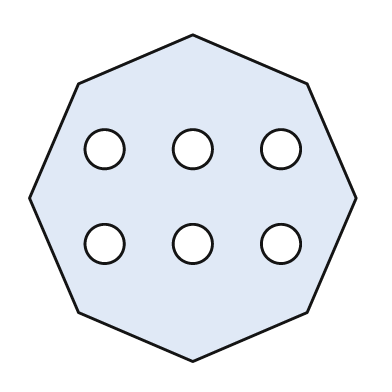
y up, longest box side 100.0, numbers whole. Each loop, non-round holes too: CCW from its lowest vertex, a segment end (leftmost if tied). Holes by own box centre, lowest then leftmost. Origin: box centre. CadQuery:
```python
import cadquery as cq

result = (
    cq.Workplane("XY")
    .moveTo(0.0, -50.0)
    .lineTo(35.0, -35.0)
    .lineTo(50.0, 0.0)
    .lineTo(35.0, 35.0)
    .lineTo(0.0, 50.0)
    .lineTo(-35.0, 35.0)
    .lineTo(-50.0, 0.0)
    .lineTo(-35.0, -35.0)
    .close()
    .moveTo(-27.0, -14.0)
    .circle(6.0)
    .moveTo(0.0, -14.0)
    .circle(6.0)
    .moveTo(27.0, -14.0)
    .circle(6.0)
    .moveTo(-27.0, 15.0)
    .circle(6.0)
    .moveTo(0.0, 15.0)
    .circle(6.0)
    .moveTo(27.0, 15.0)
    .circle(6.0)
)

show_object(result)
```